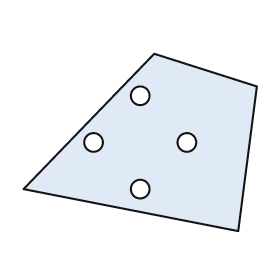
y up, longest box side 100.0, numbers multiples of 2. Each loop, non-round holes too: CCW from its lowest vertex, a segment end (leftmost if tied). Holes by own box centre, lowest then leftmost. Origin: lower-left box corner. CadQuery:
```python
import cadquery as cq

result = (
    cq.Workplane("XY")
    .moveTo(92.0, 0.0)
    .lineTo(100.0, 62.0)
    .lineTo(56.0, 76.0)
    .lineTo(0.0, 18.0)
    .close()
    .moveTo(50.0, 18.0)
    .circle(4.0)
    .moveTo(30.0, 38.0)
    .circle(4.0)
    .moveTo(70.0, 38.0)
    .circle(4.0)
    .moveTo(50.0, 58.0)
    .circle(4.0)
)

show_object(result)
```